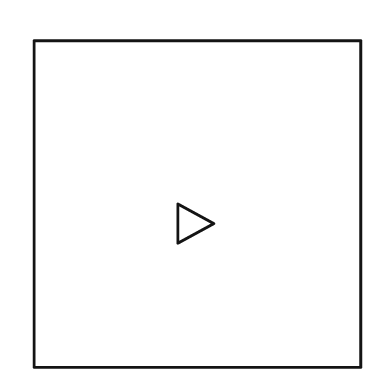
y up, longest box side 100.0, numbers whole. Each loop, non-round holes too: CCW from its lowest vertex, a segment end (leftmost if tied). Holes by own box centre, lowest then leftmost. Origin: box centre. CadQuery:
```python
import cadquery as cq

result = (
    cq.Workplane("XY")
    .moveTo(-50.0, -50.0)
    .lineTo(50.0, -50.0)
    .lineTo(50.0, 50.0)
    .lineTo(-50.0, 50.0)
    .close()
    .moveTo(-6.0, -12.0)
    .lineTo(5.0, -6.0)
    .lineTo(-6.0, 0.0)
    .close()
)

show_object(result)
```